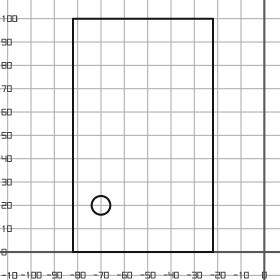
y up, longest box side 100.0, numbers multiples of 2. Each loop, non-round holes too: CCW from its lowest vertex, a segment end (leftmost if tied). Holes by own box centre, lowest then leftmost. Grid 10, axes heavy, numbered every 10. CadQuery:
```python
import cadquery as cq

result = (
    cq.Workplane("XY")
    .moveTo(-82.0, 0.0)
    .lineTo(-22.0, 0.0)
    .lineTo(-22.0, 100.0)
    .lineTo(-82.0, 100.0)
    .close()
    .moveTo(-70.0, 20.0)
    .circle(4.0)
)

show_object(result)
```